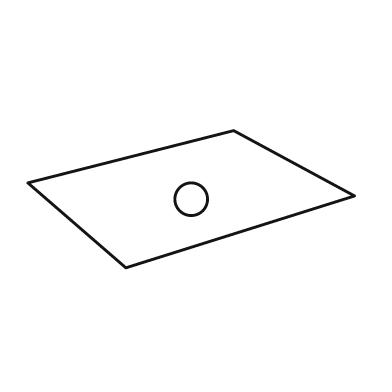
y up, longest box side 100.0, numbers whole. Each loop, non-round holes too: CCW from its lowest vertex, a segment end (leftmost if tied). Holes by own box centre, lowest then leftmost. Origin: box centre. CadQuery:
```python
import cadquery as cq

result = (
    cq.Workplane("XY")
    .moveTo(-20.0, -21.0)
    .lineTo(50.0, 1.0)
    .lineTo(13.0, 21.0)
    .lineTo(-50.0, 5.0)
    .close()
    .moveTo(0.0, 0.0)
    .circle(5.0)
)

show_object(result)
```